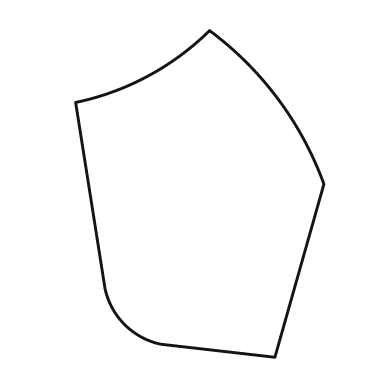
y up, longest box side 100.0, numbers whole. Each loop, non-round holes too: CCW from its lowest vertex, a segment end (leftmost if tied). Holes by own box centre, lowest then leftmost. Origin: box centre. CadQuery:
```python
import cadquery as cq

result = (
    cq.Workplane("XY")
    .moveTo(23.0, -50.0)
    .lineTo(38.0, 3.0)
    .threePointArc((24.0, 29.0), (3.0, 50.0))
    .threePointArc((-16.0, 36.0), (-38.0, 28.0))
    .lineTo(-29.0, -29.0)
    .threePointArc((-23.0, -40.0), (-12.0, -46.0))
    .close()
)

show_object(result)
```